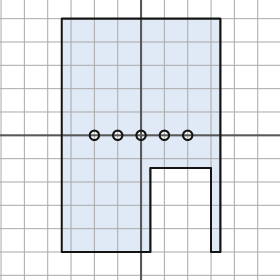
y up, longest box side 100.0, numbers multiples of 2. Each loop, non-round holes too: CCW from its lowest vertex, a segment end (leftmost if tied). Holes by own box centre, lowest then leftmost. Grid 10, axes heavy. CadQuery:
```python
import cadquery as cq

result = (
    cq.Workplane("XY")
    .moveTo(-34.0, -50.0)
    .lineTo(4.0, -50.0)
    .lineTo(4.0, -14.0)
    .lineTo(30.0, -14.0)
    .lineTo(30.0, -50.0)
    .lineTo(34.0, -50.0)
    .lineTo(34.0, 50.0)
    .lineTo(-34.0, 50.0)
    .close()
    .moveTo(-20.0, 0.0)
    .circle(2.0)
    .moveTo(-10.0, 0.0)
    .circle(2.0)
    .moveTo(0.0, 0.0)
    .circle(2.0)
    .moveTo(10.0, 0.0)
    .circle(2.0)
    .moveTo(20.0, 0.0)
    .circle(2.0)
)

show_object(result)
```